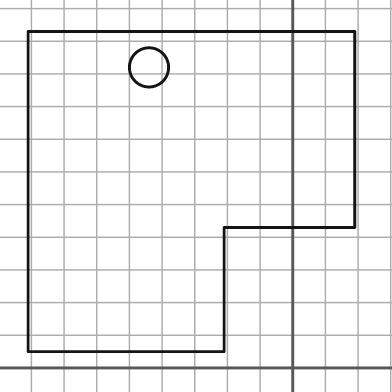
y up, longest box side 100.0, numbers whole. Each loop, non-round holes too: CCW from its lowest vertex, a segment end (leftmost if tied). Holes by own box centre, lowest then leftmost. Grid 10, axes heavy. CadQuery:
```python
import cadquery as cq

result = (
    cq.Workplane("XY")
    .moveTo(-81.0, 5.0)
    .lineTo(-21.0, 5.0)
    .lineTo(-21.0, 43.0)
    .lineTo(19.0, 43.0)
    .lineTo(19.0, 103.0)
    .lineTo(-81.0, 103.0)
    .close()
    .moveTo(-44.0, 92.0)
    .circle(6.0)
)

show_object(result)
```